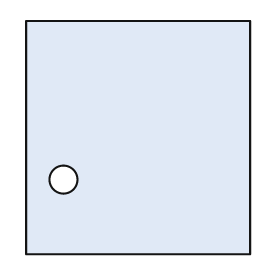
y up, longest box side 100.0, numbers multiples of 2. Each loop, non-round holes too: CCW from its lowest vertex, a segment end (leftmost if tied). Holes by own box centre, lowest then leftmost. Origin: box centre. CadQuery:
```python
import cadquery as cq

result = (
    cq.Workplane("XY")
    .moveTo(-48.0, -50.0)
    .lineTo(48.0, -50.0)
    .lineTo(48.0, 50.0)
    .lineTo(-48.0, 50.0)
    .close()
    .moveTo(-32.0, -18.0)
    .circle(6.0)
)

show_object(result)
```